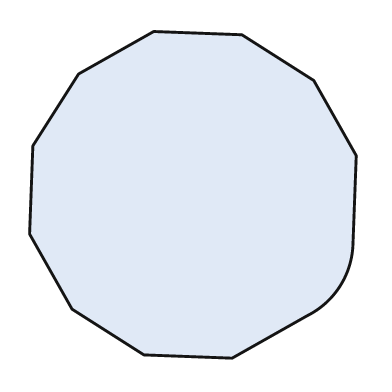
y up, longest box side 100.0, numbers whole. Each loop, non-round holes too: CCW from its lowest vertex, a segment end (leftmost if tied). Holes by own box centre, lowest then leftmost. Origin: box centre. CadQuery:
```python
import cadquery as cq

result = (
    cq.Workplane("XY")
    .moveTo(12.0, -50.0)
    .lineTo(35.0, -37.0)
    .threePointArc((45.0, -28.0), (49.0, -15.0))
    .lineTo(50.0, 12.0)
    .lineTo(37.0, 35.0)
    .lineTo(15.0, 49.0)
    .lineTo(-12.0, 50.0)
    .lineTo(-35.0, 37.0)
    .lineTo(-49.0, 15.0)
    .lineTo(-50.0, -12.0)
    .lineTo(-37.0, -35.0)
    .lineTo(-15.0, -49.0)
    .close()
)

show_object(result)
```